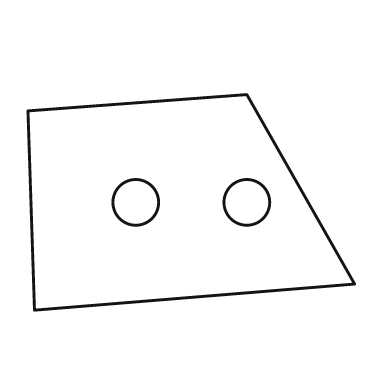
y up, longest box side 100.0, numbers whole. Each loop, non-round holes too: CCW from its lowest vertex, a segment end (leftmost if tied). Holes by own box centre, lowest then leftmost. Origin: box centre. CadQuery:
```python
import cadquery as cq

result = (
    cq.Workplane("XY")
    .moveTo(-48.0, -33.0)
    .lineTo(50.0, -25.0)
    .lineTo(17.0, 33.0)
    .lineTo(-50.0, 28.0)
    .close()
    .moveTo(-17.0, 0.0)
    .circle(7.0)
    .moveTo(17.0, 0.0)
    .circle(7.0)
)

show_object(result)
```